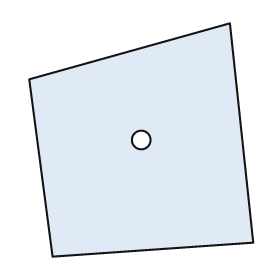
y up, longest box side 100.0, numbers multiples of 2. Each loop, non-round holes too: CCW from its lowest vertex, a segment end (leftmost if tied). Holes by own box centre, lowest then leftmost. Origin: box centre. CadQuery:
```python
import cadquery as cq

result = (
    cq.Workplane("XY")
    .moveTo(-38.0, -50.0)
    .lineTo(48.0, -44.0)
    .lineTo(38.0, 50.0)
    .lineTo(-48.0, 26.0)
    .close()
    .moveTo(0.0, 0.0)
    .circle(4.0)
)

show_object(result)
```